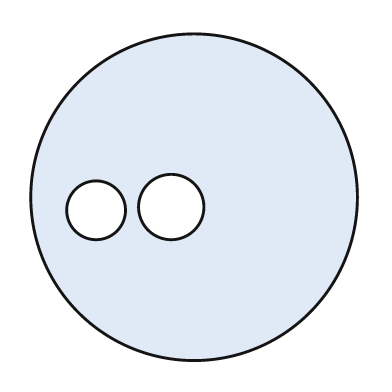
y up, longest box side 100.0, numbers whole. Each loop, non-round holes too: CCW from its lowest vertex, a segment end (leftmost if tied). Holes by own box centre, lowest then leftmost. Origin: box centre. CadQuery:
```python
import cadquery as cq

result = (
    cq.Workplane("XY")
    .moveTo(0.0, 0.0)
    .circle(50.0)
    .moveTo(-30.0, -4.0)
    .circle(9.0)
    .moveTo(-7.0, -3.0)
    .circle(10.0)
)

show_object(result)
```